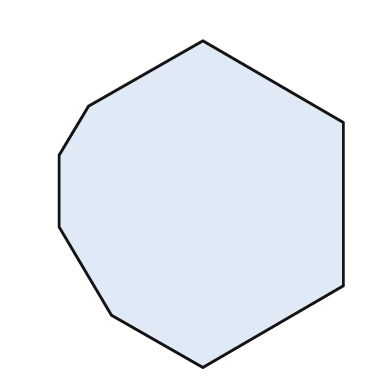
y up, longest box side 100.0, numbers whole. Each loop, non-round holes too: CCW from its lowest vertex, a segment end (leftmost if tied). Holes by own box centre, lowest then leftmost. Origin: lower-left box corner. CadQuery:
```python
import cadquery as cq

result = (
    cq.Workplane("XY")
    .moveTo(44.0, 0.0)
    .lineTo(87.0, 25.0)
    .lineTo(87.0, 75.0)
    .lineTo(44.0, 100.0)
    .lineTo(9.0, 80.0)
    .lineTo(0.0, 65.0)
    .lineTo(0.0, 43.0)
    .lineTo(16.0, 16.0)
    .close()
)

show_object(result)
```